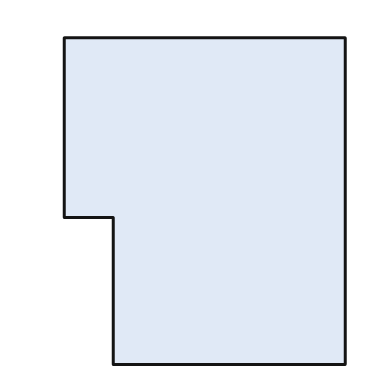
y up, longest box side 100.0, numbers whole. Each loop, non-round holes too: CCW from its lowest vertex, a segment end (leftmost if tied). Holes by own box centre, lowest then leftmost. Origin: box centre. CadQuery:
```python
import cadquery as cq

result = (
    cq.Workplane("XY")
    .moveTo(-28.0, -50.0)
    .lineTo(43.0, -50.0)
    .lineTo(43.0, 50.0)
    .lineTo(-43.0, 50.0)
    .lineTo(-43.0, -5.0)
    .lineTo(-28.0, -5.0)
    .close()
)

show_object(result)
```